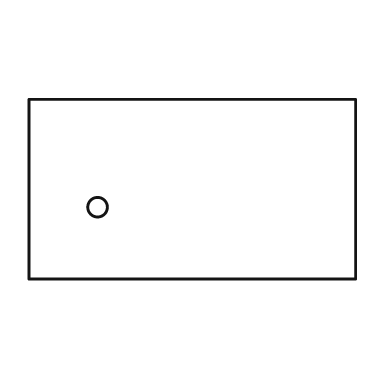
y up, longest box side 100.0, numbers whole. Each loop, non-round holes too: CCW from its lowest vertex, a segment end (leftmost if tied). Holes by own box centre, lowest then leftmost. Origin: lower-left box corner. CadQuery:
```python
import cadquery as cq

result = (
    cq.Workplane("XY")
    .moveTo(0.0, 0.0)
    .lineTo(100.0, 0.0)
    .lineTo(100.0, 55.0)
    .lineTo(0.0, 55.0)
    .close()
    .moveTo(21.0, 22.0)
    .circle(3.0)
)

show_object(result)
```